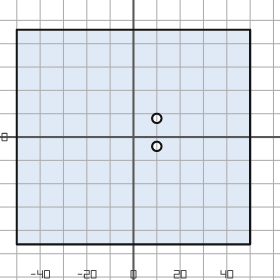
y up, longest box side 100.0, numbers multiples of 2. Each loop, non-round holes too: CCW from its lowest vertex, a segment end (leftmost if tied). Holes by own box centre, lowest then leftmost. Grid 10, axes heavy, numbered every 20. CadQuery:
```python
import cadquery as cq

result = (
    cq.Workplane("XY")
    .moveTo(-50.0, -46.0)
    .lineTo(50.0, -46.0)
    .lineTo(50.0, 46.0)
    .lineTo(-50.0, 46.0)
    .close()
    .moveTo(10.0, -4.0)
    .circle(2.0)
    .moveTo(10.0, 8.0)
    .circle(2.0)
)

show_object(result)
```